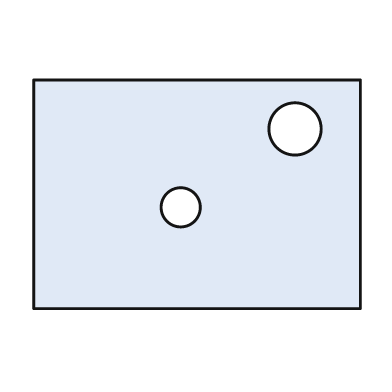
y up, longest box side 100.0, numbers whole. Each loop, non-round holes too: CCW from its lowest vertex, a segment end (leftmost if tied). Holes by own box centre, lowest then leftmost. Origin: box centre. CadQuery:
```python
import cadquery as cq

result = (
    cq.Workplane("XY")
    .moveTo(-50.0, -35.0)
    .lineTo(50.0, -35.0)
    .lineTo(50.0, 35.0)
    .lineTo(-50.0, 35.0)
    .close()
    .moveTo(-5.0, -4.0)
    .circle(6.0)
    .moveTo(30.0, 20.0)
    .circle(8.0)
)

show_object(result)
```